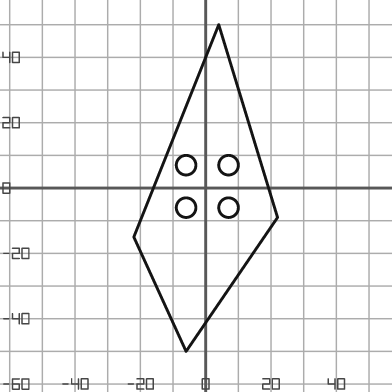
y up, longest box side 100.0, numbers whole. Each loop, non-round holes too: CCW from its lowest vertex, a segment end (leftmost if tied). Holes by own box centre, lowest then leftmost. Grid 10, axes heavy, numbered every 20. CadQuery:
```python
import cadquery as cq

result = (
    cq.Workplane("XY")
    .moveTo(-6.0, -50.0)
    .lineTo(22.0, -9.0)
    .lineTo(4.0, 50.0)
    .lineTo(-22.0, -15.0)
    .close()
    .moveTo(-6.0, -6.0)
    .circle(3.0)
    .moveTo(7.0, -6.0)
    .circle(3.0)
    .moveTo(-6.0, 7.0)
    .circle(3.0)
    .moveTo(7.0, 7.0)
    .circle(3.0)
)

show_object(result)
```